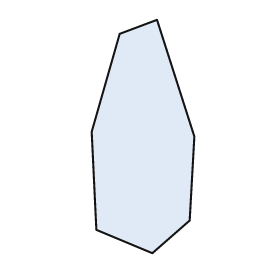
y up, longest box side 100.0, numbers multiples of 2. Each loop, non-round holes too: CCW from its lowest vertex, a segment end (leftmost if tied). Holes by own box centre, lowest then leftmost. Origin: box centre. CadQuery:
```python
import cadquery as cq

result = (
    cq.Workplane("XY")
    .moveTo(4.0, -50.0)
    .lineTo(20.0, -36.0)
    .lineTo(22.0, 0.0)
    .lineTo(6.0, 50.0)
    .lineTo(-10.0, 44.0)
    .lineTo(-22.0, 2.0)
    .lineTo(-20.0, -40.0)
    .close()
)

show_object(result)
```